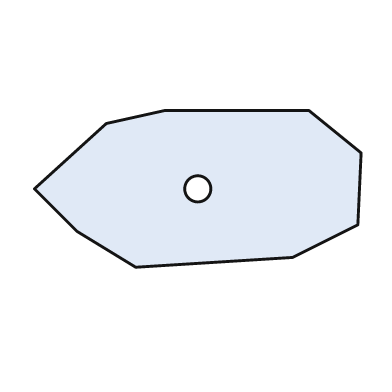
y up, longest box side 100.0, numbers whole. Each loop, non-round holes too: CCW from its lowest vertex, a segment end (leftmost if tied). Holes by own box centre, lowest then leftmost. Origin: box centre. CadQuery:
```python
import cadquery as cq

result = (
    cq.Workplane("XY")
    .moveTo(-19.0, -24.0)
    .lineTo(29.0, -21.0)
    .lineTo(49.0, -11.0)
    .lineTo(50.0, 11.0)
    .lineTo(34.0, 24.0)
    .lineTo(-10.0, 24.0)
    .lineTo(-28.0, 20.0)
    .lineTo(-50.0, 0.0)
    .lineTo(-37.0, -13.0)
    .close()
    .moveTo(0.0, 0.0)
    .circle(4.0)
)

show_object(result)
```